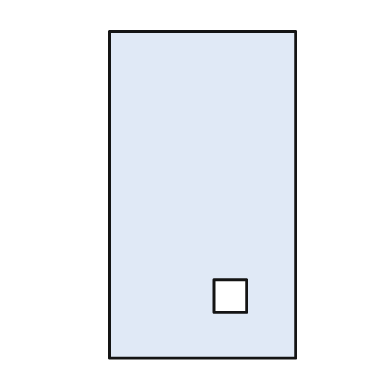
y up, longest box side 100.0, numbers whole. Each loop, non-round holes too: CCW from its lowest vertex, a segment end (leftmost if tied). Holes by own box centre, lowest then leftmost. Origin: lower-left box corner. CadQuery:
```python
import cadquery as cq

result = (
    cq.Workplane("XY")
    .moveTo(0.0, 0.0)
    .lineTo(57.0, 0.0)
    .lineTo(57.0, 100.0)
    .lineTo(0.0, 100.0)
    .close()
    .moveTo(32.0, 14.0)
    .lineTo(42.0, 14.0)
    .lineTo(42.0, 24.0)
    .lineTo(32.0, 24.0)
    .close()
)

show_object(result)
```